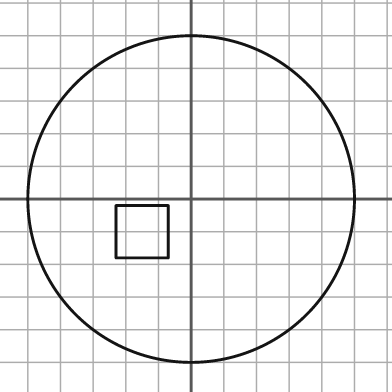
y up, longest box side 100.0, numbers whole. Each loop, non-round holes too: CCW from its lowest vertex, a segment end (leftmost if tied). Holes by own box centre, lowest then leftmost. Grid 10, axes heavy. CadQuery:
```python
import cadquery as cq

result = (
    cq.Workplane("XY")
    .moveTo(0.0, 0.0)
    .circle(50.0)
    .moveTo(-23.0, -18.0)
    .lineTo(-7.0, -18.0)
    .lineTo(-7.0, -2.0)
    .lineTo(-23.0, -2.0)
    .close()
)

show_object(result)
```